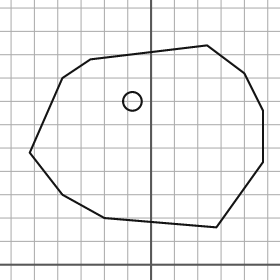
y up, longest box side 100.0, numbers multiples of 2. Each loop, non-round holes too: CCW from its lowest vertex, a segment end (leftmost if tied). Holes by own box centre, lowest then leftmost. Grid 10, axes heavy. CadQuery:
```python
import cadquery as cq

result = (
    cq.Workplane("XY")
    .moveTo(28.0, 16.0)
    .lineTo(48.0, 44.0)
    .lineTo(48.0, 66.0)
    .lineTo(40.0, 82.0)
    .lineTo(24.0, 94.0)
    .lineTo(-26.0, 88.0)
    .lineTo(-38.0, 80.0)
    .lineTo(-52.0, 48.0)
    .lineTo(-38.0, 30.0)
    .lineTo(-20.0, 20.0)
    .close()
    .moveTo(-8.0, 70.0)
    .circle(4.0)
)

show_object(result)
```